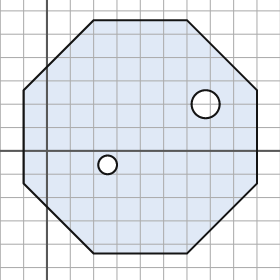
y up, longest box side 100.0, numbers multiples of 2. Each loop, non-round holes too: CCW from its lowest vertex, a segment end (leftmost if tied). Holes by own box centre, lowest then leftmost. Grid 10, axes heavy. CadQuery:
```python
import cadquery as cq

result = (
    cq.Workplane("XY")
    .moveTo(20.0, -44.0)
    .lineTo(60.0, -44.0)
    .lineTo(90.0, -14.0)
    .lineTo(90.0, 26.0)
    .lineTo(60.0, 56.0)
    .lineTo(20.0, 56.0)
    .lineTo(-10.0, 26.0)
    .lineTo(-10.0, -14.0)
    .close()
    .moveTo(26.0, -6.0)
    .circle(4.0)
    .moveTo(68.0, 20.0)
    .circle(6.0)
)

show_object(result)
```